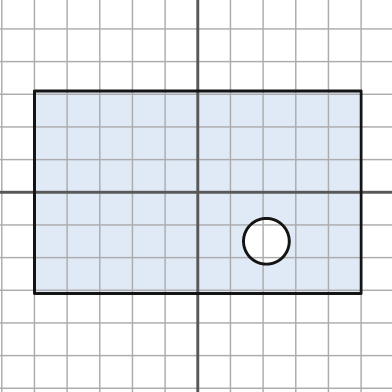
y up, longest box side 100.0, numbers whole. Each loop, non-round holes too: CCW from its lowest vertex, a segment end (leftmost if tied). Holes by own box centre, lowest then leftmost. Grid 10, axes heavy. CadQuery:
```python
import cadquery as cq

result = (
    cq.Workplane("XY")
    .moveTo(-50.0, -31.0)
    .lineTo(50.0, -31.0)
    .lineTo(50.0, 31.0)
    .lineTo(-50.0, 31.0)
    .close()
    .moveTo(21.0, -15.0)
    .circle(7.0)
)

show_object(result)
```